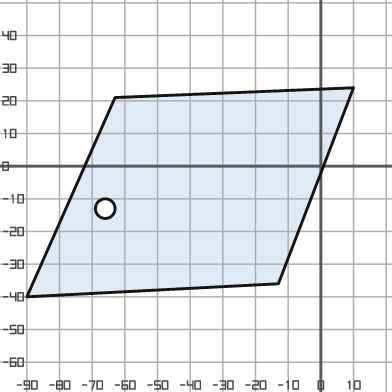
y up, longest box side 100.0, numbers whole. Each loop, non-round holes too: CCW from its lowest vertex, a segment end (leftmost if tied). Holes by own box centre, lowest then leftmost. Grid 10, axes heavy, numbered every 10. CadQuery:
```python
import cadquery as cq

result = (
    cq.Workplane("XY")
    .moveTo(-90.0, -40.0)
    .lineTo(-13.0, -36.0)
    .lineTo(10.0, 24.0)
    .lineTo(-63.0, 21.0)
    .close()
    .moveTo(-66.0, -13.0)
    .circle(3.0)
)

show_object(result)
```